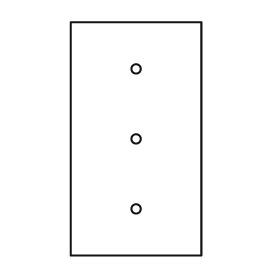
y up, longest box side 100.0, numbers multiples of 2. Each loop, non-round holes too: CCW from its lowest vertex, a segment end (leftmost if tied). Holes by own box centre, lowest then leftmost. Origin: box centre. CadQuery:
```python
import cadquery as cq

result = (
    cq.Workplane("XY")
    .moveTo(-28.0, -50.0)
    .lineTo(28.0, -50.0)
    .lineTo(28.0, 50.0)
    .lineTo(-28.0, 50.0)
    .close()
    .moveTo(0.0, -30.0)
    .circle(2.0)
    .moveTo(0.0, 0.0)
    .circle(2.0)
    .moveTo(0.0, 30.0)
    .circle(2.0)
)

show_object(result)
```